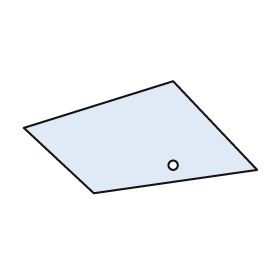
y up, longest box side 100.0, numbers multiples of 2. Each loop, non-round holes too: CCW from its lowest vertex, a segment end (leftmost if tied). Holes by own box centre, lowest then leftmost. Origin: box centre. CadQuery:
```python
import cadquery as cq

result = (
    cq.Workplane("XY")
    .moveTo(-20.0, -24.0)
    .lineTo(50.0, -14.0)
    .lineTo(14.0, 24.0)
    .lineTo(-50.0, 4.0)
    .close()
    .moveTo(14.0, -12.0)
    .circle(2.0)
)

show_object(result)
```